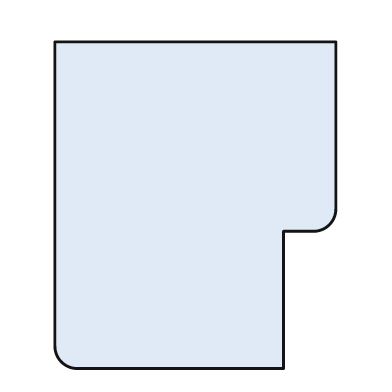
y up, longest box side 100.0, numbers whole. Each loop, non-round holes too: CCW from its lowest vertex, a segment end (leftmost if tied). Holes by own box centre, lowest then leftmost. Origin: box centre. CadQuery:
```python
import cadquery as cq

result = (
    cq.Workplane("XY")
    .moveTo(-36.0, -50.0)
    .lineTo(27.0, -50.0)
    .lineTo(27.0, -8.0)
    .lineTo(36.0, -8.0)
    .threePointArc((41.0, -6.0), (43.0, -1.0))
    .lineTo(43.0, 50.0)
    .lineTo(-43.0, 50.0)
    .lineTo(-43.0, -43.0)
    .threePointArc((-41.0, -48.0), (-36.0, -50.0))
    .close()
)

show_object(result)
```